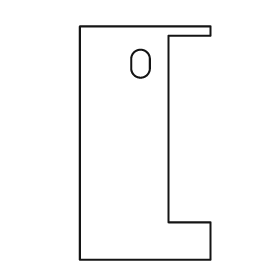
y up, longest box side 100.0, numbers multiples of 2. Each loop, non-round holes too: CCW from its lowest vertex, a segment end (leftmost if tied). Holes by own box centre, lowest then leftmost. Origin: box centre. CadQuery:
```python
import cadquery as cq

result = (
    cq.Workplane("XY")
    .moveTo(-28.0, -50.0)
    .lineTo(28.0, -50.0)
    .lineTo(28.0, -34.0)
    .lineTo(10.0, -34.0)
    .lineTo(10.0, 46.0)
    .lineTo(28.0, 46.0)
    .lineTo(28.0, 50.0)
    .lineTo(-28.0, 50.0)
    .close()
    .moveTo(-6.0, 32.0)
    .threePointArc((-2.0, 28.0), (2.0, 32.0))
    .lineTo(2.0, 36.0)
    .threePointArc((-2.0, 40.0), (-6.0, 36.0))
    .close()
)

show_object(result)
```